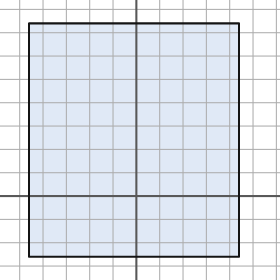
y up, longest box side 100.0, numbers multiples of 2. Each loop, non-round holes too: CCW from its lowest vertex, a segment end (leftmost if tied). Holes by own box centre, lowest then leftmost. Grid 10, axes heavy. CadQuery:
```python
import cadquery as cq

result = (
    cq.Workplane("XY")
    .moveTo(-46.0, -26.0)
    .lineTo(44.0, -26.0)
    .lineTo(44.0, 74.0)
    .lineTo(-46.0, 74.0)
    .close()
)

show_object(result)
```